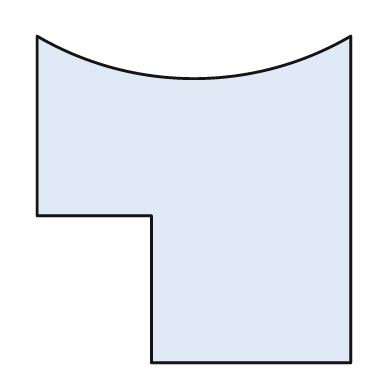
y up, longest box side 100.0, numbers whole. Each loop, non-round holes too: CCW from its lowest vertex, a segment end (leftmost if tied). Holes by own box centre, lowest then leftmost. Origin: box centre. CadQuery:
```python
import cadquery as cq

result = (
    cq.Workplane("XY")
    .moveTo(-13.0, -50.0)
    .lineTo(48.0, -50.0)
    .lineTo(48.0, 50.0)
    .threePointArc((0.0, 37.0), (-48.0, 50.0))
    .lineTo(-48.0, -5.0)
    .lineTo(-13.0, -5.0)
    .close()
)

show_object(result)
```